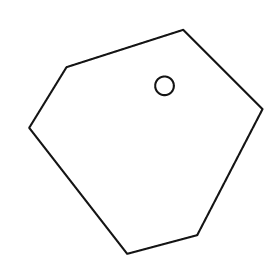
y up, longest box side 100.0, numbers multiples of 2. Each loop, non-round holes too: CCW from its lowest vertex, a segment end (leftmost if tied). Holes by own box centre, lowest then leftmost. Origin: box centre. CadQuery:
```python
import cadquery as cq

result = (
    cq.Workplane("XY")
    .moveTo(-8.0, -48.0)
    .lineTo(22.0, -40.0)
    .lineTo(50.0, 14.0)
    .lineTo(16.0, 48.0)
    .lineTo(-34.0, 32.0)
    .lineTo(-50.0, 6.0)
    .close()
    .moveTo(8.0, 24.0)
    .circle(4.0)
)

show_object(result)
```